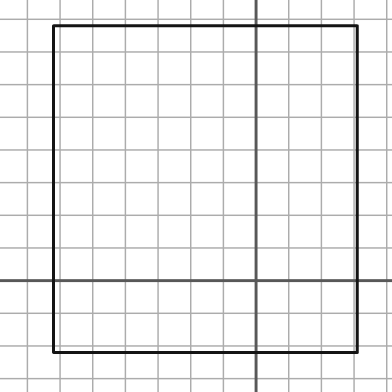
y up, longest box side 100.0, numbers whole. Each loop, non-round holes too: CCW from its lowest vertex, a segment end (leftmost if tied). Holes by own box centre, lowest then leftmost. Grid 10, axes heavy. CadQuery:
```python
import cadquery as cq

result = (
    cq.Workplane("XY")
    .moveTo(-62.0, -22.0)
    .lineTo(31.0, -22.0)
    .lineTo(31.0, 78.0)
    .lineTo(-62.0, 78.0)
    .close()
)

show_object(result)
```